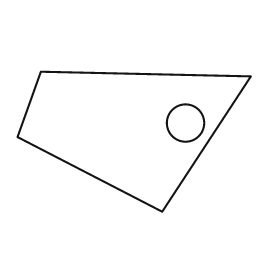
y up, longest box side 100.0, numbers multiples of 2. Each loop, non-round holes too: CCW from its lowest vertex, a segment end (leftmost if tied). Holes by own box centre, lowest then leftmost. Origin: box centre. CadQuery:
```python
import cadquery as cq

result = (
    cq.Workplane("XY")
    .moveTo(12.0, -30.0)
    .lineTo(50.0, 28.0)
    .lineTo(-40.0, 30.0)
    .lineTo(-50.0, 2.0)
    .close()
    .moveTo(22.0, 8.0)
    .circle(8.0)
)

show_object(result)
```